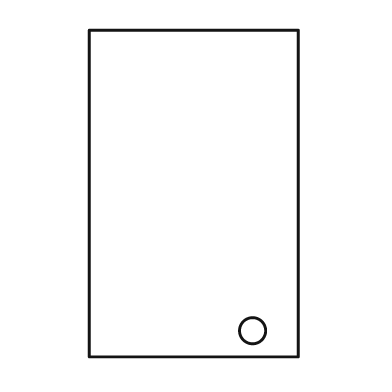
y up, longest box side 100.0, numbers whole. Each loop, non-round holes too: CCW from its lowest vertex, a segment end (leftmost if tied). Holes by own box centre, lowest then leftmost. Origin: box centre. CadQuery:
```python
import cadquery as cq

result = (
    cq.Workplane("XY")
    .moveTo(-32.0, -50.0)
    .lineTo(32.0, -50.0)
    .lineTo(32.0, 50.0)
    .lineTo(-32.0, 50.0)
    .close()
    .moveTo(18.0, -42.0)
    .circle(4.0)
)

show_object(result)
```